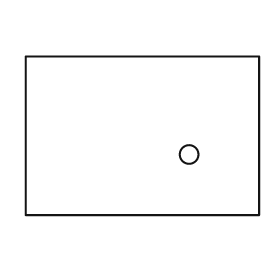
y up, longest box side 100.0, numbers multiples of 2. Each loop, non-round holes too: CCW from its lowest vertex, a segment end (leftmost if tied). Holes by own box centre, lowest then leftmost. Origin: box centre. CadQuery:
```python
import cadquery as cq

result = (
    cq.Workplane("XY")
    .moveTo(-50.0, -34.0)
    .lineTo(50.0, -34.0)
    .lineTo(50.0, 34.0)
    .lineTo(-50.0, 34.0)
    .close()
    .moveTo(20.0, -8.0)
    .circle(4.0)
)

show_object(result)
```